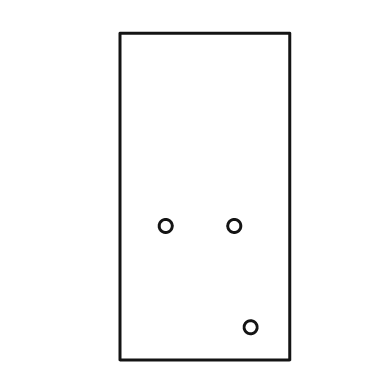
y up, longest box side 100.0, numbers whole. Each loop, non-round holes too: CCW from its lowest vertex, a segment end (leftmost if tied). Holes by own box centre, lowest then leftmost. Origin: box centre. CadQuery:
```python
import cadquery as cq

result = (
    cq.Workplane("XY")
    .moveTo(-26.0, -50.0)
    .lineTo(26.0, -50.0)
    .lineTo(26.0, 50.0)
    .lineTo(-26.0, 50.0)
    .close()
    .moveTo(14.0, -40.0)
    .circle(2.0)
    .moveTo(-12.0, -9.0)
    .circle(2.0)
    .moveTo(9.0, -9.0)
    .circle(2.0)
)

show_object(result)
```